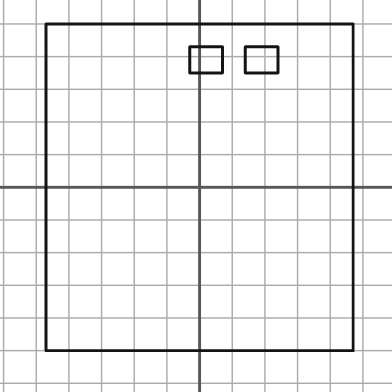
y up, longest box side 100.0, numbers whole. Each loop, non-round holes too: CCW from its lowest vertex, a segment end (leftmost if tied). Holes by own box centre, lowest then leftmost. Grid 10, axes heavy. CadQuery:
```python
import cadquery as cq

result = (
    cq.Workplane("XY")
    .moveTo(-47.0, -50.0)
    .lineTo(47.0, -50.0)
    .lineTo(47.0, 50.0)
    .lineTo(-47.0, 50.0)
    .close()
    .moveTo(-3.0, 35.0)
    .lineTo(7.0, 35.0)
    .lineTo(7.0, 43.0)
    .lineTo(-3.0, 43.0)
    .close()
    .moveTo(14.0, 35.0)
    .lineTo(24.0, 35.0)
    .lineTo(24.0, 43.0)
    .lineTo(14.0, 43.0)
    .close()
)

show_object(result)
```